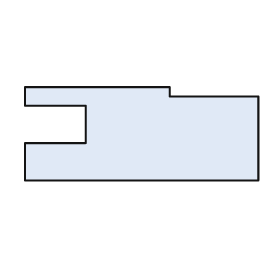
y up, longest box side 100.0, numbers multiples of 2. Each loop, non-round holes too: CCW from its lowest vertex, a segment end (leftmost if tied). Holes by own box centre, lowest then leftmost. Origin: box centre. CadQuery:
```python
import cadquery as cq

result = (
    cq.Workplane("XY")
    .moveTo(-50.0, -20.0)
    .lineTo(50.0, -20.0)
    .lineTo(50.0, 16.0)
    .lineTo(12.0, 16.0)
    .lineTo(12.0, 20.0)
    .lineTo(-50.0, 20.0)
    .lineTo(-50.0, 12.0)
    .lineTo(-24.0, 12.0)
    .lineTo(-24.0, -4.0)
    .lineTo(-50.0, -4.0)
    .close()
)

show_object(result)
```